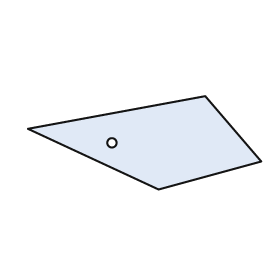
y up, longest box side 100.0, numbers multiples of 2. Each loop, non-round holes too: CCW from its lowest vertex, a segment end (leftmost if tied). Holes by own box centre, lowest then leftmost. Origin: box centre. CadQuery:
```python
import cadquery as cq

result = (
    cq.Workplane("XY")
    .moveTo(6.0, -20.0)
    .lineTo(50.0, -8.0)
    .lineTo(26.0, 20.0)
    .lineTo(-50.0, 6.0)
    .close()
    .moveTo(-14.0, 0.0)
    .circle(2.0)
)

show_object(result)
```